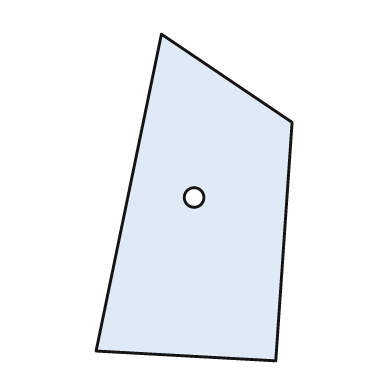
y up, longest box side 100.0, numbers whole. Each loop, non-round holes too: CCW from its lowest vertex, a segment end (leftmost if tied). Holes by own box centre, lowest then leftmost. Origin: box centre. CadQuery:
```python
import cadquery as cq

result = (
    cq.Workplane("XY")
    .moveTo(25.0, -50.0)
    .lineTo(30.0, 23.0)
    .lineTo(-10.0, 50.0)
    .lineTo(-30.0, -47.0)
    .close()
    .moveTo(0.0, 0.0)
    .circle(3.0)
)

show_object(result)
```